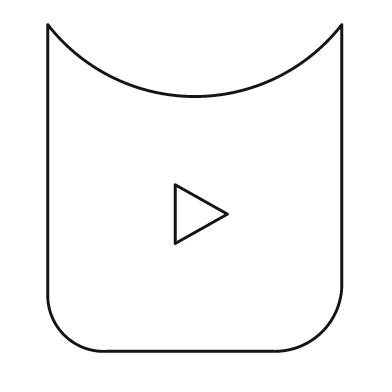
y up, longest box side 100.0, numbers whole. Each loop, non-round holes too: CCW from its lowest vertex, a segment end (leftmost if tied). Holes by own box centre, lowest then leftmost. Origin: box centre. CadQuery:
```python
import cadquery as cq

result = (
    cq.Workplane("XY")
    .moveTo(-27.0, -50.0)
    .lineTo(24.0, -50.0)
    .threePointArc((39.0, -44.0), (45.0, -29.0))
    .lineTo(45.0, 50.0)
    .threePointArc((0.0, 28.0), (-45.0, 50.0))
    .lineTo(-45.0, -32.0)
    .threePointArc((-40.0, -45.0), (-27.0, -50.0))
    .close()
    .moveTo(-6.0, -17.0)
    .lineTo(10.0, -8.0)
    .lineTo(-6.0, 1.0)
    .close()
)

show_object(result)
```